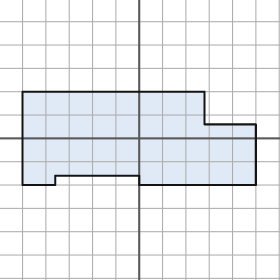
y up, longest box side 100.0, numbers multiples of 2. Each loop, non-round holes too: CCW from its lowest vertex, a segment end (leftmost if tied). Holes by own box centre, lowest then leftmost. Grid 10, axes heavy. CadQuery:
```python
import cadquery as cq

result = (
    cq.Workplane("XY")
    .moveTo(-50.0, -20.0)
    .lineTo(-36.0, -20.0)
    .lineTo(-36.0, -16.0)
    .lineTo(0.0, -16.0)
    .lineTo(0.0, -20.0)
    .lineTo(50.0, -20.0)
    .lineTo(50.0, 6.0)
    .lineTo(28.0, 6.0)
    .lineTo(28.0, 20.0)
    .lineTo(-50.0, 20.0)
    .close()
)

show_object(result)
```